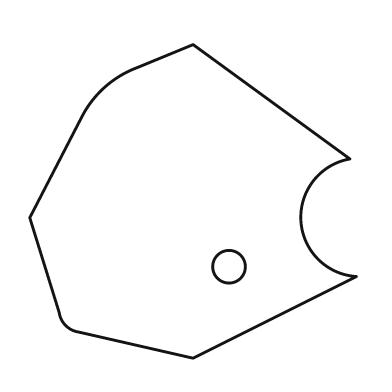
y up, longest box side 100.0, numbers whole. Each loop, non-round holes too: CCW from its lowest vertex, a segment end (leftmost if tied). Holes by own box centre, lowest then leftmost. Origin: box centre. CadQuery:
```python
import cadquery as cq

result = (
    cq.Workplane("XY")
    .moveTo(0.0, -48.0)
    .lineTo(50.0, -23.0)
    .threePointArc((33.0, -6.0), (48.0, 13.0))
    .lineTo(0.0, 48.0)
    .lineTo(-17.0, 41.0)
    .threePointArc((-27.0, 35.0), (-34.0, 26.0))
    .lineTo(-50.0, -5.0)
    .lineTo(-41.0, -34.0)
    .threePointArc((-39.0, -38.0), (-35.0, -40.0))
    .close()
    .moveTo(11.0, -20.0)
    .circle(5.0)
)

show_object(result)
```